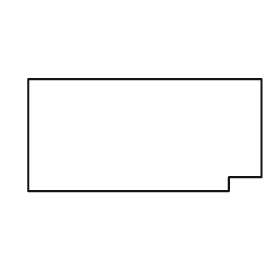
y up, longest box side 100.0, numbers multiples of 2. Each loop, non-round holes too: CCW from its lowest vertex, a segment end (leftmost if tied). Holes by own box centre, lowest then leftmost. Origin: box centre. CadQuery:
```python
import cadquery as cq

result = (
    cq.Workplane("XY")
    .moveTo(-50.0, -24.0)
    .lineTo(36.0, -24.0)
    .lineTo(36.0, -18.0)
    .lineTo(50.0, -18.0)
    .lineTo(50.0, 24.0)
    .lineTo(-50.0, 24.0)
    .close()
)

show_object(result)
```